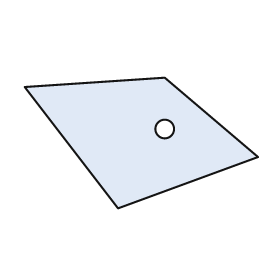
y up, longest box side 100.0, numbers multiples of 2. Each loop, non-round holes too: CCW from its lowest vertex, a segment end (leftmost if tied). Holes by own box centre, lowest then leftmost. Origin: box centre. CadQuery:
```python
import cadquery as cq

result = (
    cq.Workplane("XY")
    .moveTo(-10.0, -28.0)
    .lineTo(50.0, -6.0)
    .lineTo(10.0, 28.0)
    .lineTo(-50.0, 24.0)
    .close()
    .moveTo(10.0, 6.0)
    .circle(4.0)
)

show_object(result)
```